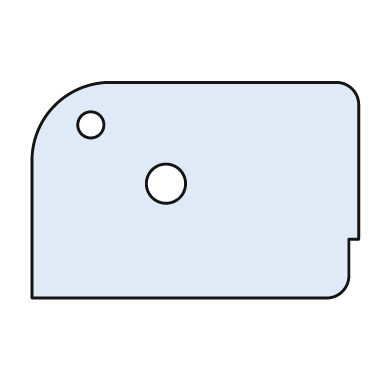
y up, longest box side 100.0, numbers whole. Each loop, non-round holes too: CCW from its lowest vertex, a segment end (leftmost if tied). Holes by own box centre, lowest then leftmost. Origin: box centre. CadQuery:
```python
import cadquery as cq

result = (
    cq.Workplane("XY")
    .moveTo(-50.0, -33.0)
    .lineTo(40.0, -33.0)
    .threePointArc((45.0, -31.0), (47.0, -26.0))
    .lineTo(47.0, -15.0)
    .lineTo(50.0, -15.0)
    .lineTo(50.0, 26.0)
    .threePointArc((48.0, 31.0), (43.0, 33.0))
    .lineTo(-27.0, 33.0)
    .threePointArc((-43.0, 26.0), (-50.0, 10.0))
    .close()
    .moveTo(-9.0, 2.0)
    .circle(6.0)
    .moveTo(-32.0, 20.0)
    .circle(4.0)
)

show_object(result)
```